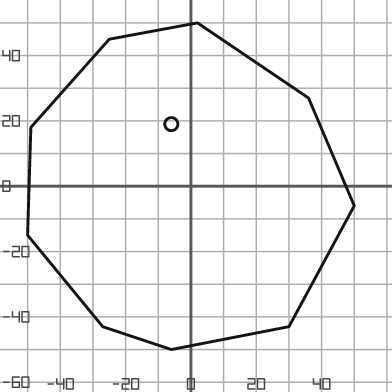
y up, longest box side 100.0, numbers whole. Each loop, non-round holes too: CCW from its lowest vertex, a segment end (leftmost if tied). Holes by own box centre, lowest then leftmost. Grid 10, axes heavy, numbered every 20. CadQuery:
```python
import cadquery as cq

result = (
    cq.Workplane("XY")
    .moveTo(-6.0, -50.0)
    .lineTo(30.0, -43.0)
    .lineTo(50.0, -6.0)
    .lineTo(36.0, 27.0)
    .lineTo(2.0, 50.0)
    .lineTo(-25.0, 45.0)
    .lineTo(-49.0, 18.0)
    .lineTo(-50.0, -15.0)
    .lineTo(-27.0, -43.0)
    .close()
    .moveTo(-6.0, 19.0)
    .circle(2.0)
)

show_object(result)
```